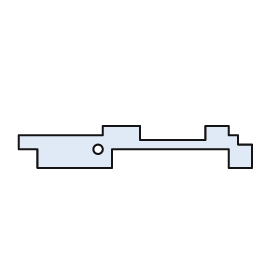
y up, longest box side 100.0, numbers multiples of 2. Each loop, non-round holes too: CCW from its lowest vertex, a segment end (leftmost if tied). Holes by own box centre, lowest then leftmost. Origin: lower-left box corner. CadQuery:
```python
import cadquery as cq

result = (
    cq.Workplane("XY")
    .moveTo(8.0, 0.0)
    .lineTo(40.0, 0.0)
    .lineTo(40.0, 8.0)
    .lineTo(90.0, 8.0)
    .lineTo(90.0, 0.0)
    .lineTo(100.0, 0.0)
    .lineTo(100.0, 10.0)
    .lineTo(94.0, 10.0)
    .lineTo(94.0, 14.0)
    .lineTo(90.0, 14.0)
    .lineTo(90.0, 18.0)
    .lineTo(80.0, 18.0)
    .lineTo(80.0, 12.0)
    .lineTo(52.0, 12.0)
    .lineTo(52.0, 18.0)
    .lineTo(36.0, 18.0)
    .lineTo(36.0, 14.0)
    .lineTo(0.0, 14.0)
    .lineTo(0.0, 8.0)
    .lineTo(8.0, 8.0)
    .close()
    .moveTo(34.0, 8.0)
    .circle(2.0)
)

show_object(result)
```